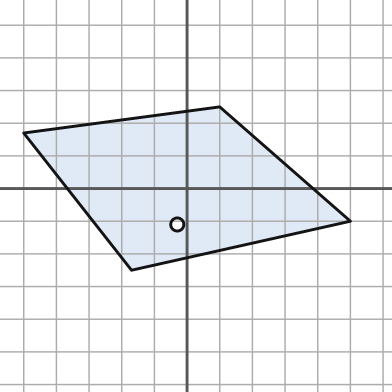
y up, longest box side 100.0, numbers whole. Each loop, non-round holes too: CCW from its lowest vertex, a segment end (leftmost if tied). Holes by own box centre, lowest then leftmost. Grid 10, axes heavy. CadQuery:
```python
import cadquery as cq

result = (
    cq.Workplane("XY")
    .moveTo(-17.0, -25.0)
    .lineTo(50.0, -10.0)
    .lineTo(10.0, 25.0)
    .lineTo(-50.0, 17.0)
    .close()
    .moveTo(-3.0, -11.0)
    .circle(2.0)
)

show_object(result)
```